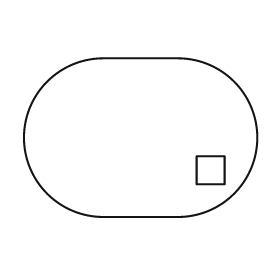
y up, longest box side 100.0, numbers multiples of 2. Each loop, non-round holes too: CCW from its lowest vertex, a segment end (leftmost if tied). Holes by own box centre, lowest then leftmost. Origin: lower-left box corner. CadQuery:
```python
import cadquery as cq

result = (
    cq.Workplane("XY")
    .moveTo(34.0, 0.0)
    .lineTo(66.0, 0.0)
    .threePointArc((100.0, 34.0), (66.0, 68.0))
    .lineTo(34.0, 68.0)
    .threePointArc((0.0, 34.0), (34.0, 0.0))
    .close()
    .moveTo(74.0, 14.0)
    .lineTo(86.0, 14.0)
    .lineTo(86.0, 26.0)
    .lineTo(74.0, 26.0)
    .close()
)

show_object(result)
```